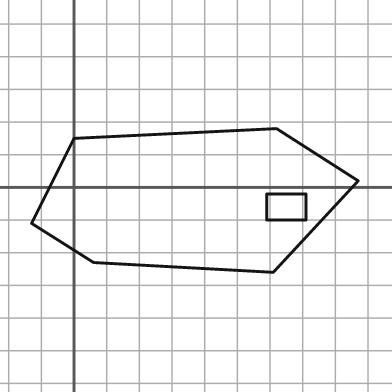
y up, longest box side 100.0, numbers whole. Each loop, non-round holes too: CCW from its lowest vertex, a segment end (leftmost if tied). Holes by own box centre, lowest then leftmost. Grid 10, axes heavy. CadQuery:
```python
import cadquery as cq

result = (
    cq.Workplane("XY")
    .moveTo(61.0, -26.0)
    .lineTo(87.0, 2.0)
    .lineTo(62.0, 18.0)
    .lineTo(0.0, 15.0)
    .lineTo(-13.0, -11.0)
    .lineTo(6.0, -23.0)
    .close()
    .moveTo(59.0, -10.0)
    .lineTo(71.0, -10.0)
    .lineTo(71.0, -2.0)
    .lineTo(59.0, -2.0)
    .close()
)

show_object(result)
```